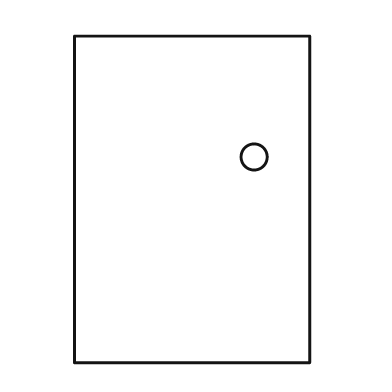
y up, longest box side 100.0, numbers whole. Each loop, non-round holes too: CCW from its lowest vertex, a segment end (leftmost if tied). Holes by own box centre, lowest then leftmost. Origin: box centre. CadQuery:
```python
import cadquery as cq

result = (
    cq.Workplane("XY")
    .moveTo(-36.0, -50.0)
    .lineTo(36.0, -50.0)
    .lineTo(36.0, 50.0)
    .lineTo(-36.0, 50.0)
    .close()
    .moveTo(19.0, 13.0)
    .circle(4.0)
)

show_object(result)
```